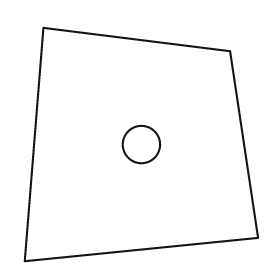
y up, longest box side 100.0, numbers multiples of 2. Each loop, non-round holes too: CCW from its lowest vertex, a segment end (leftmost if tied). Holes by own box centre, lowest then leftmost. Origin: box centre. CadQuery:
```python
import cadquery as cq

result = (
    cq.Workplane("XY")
    .moveTo(-50.0, -50.0)
    .lineTo(50.0, -40.0)
    .lineTo(38.0, 40.0)
    .lineTo(-42.0, 50.0)
    .close()
    .moveTo(0.0, 0.0)
    .circle(8.0)
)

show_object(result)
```